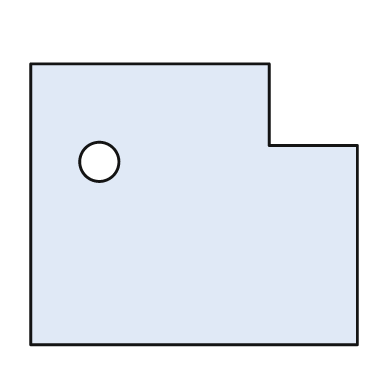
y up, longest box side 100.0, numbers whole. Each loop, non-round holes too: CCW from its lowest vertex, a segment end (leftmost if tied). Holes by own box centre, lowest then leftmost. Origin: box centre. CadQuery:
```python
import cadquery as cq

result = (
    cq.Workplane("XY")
    .moveTo(-50.0, -43.0)
    .lineTo(50.0, -43.0)
    .lineTo(50.0, 18.0)
    .lineTo(23.0, 18.0)
    .lineTo(23.0, 43.0)
    .lineTo(-50.0, 43.0)
    .close()
    .moveTo(-29.0, 13.0)
    .circle(6.0)
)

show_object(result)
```